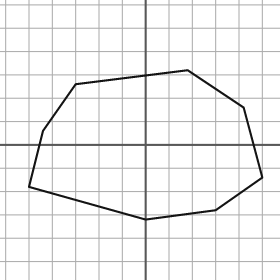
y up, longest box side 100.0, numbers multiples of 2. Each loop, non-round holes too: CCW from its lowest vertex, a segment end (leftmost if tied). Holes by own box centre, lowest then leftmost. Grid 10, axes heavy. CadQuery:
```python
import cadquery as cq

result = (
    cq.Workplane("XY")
    .moveTo(0.0, -32.0)
    .lineTo(30.0, -28.0)
    .lineTo(50.0, -14.0)
    .lineTo(42.0, 16.0)
    .lineTo(18.0, 32.0)
    .lineTo(-30.0, 26.0)
    .lineTo(-44.0, 6.0)
    .lineTo(-50.0, -18.0)
    .close()
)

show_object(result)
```